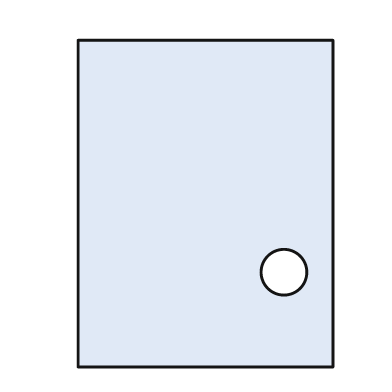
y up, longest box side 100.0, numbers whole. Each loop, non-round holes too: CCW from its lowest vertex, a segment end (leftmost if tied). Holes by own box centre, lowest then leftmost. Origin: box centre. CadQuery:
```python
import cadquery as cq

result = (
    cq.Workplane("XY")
    .moveTo(-39.0, -50.0)
    .lineTo(39.0, -50.0)
    .lineTo(39.0, 50.0)
    .lineTo(-39.0, 50.0)
    .close()
    .moveTo(24.0, -21.0)
    .circle(7.0)
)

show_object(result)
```